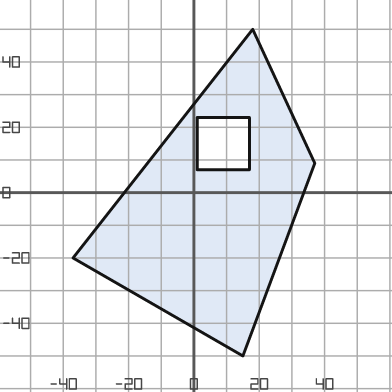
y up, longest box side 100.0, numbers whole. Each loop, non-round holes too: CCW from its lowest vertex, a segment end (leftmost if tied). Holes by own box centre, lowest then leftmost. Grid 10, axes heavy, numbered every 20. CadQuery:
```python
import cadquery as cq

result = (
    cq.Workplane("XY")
    .moveTo(15.0, -50.0)
    .lineTo(37.0, 9.0)
    .lineTo(18.0, 50.0)
    .lineTo(-37.0, -20.0)
    .close()
    .moveTo(1.0, 7.0)
    .lineTo(17.0, 7.0)
    .lineTo(17.0, 23.0)
    .lineTo(1.0, 23.0)
    .close()
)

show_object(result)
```